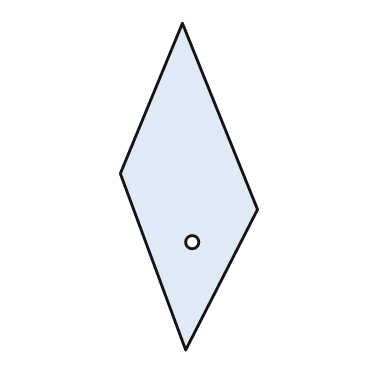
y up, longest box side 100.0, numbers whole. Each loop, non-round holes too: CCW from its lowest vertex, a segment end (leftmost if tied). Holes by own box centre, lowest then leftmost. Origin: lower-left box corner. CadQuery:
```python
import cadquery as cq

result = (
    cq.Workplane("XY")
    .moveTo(20.0, 0.0)
    .lineTo(42.0, 43.0)
    .lineTo(19.0, 100.0)
    .lineTo(0.0, 54.0)
    .close()
    .moveTo(22.0, 33.0)
    .circle(2.0)
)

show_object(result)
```